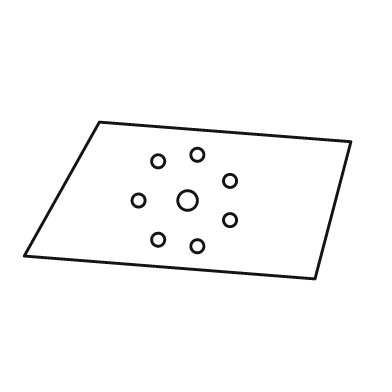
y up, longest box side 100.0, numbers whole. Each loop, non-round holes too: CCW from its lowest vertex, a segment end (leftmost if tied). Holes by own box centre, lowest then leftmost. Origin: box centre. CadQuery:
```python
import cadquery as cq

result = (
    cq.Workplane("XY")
    .moveTo(39.0, -24.0)
    .lineTo(50.0, 18.0)
    .lineTo(-27.0, 24.0)
    .lineTo(-50.0, -17.0)
    .close()
    .moveTo(3.0, -14.0)
    .circle(2.0)
    .moveTo(-9.0, -12.0)
    .circle(2.0)
    .moveTo(13.0, -6.0)
    .circle(2.0)
    .moveTo(-15.0, 0.0)
    .circle(2.0)
    .moveTo(0.0, 0.0)
    .circle(3.0)
    .moveTo(13.0, 6.0)
    .circle(2.0)
    .moveTo(-9.0, 12.0)
    .circle(2.0)
    .moveTo(3.0, 14.0)
    .circle(2.0)
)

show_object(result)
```